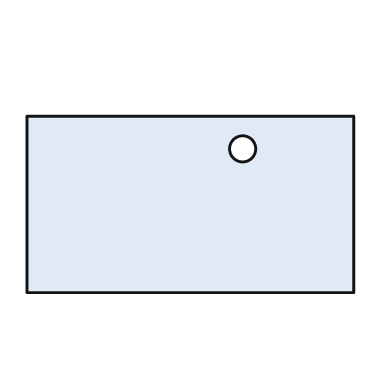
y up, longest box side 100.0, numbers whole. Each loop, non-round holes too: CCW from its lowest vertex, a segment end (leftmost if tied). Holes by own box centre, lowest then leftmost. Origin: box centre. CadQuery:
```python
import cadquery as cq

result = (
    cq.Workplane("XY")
    .moveTo(-50.0, -27.0)
    .lineTo(50.0, -27.0)
    .lineTo(50.0, 27.0)
    .lineTo(-50.0, 27.0)
    .close()
    .moveTo(16.0, 17.0)
    .circle(4.0)
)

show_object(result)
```